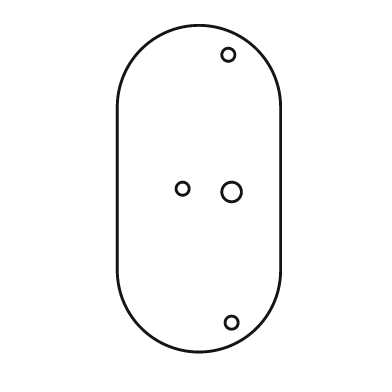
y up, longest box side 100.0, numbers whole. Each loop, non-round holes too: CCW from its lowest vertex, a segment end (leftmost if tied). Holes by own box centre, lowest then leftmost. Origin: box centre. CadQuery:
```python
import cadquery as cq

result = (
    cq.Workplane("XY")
    .moveTo(-25.0, -25.0)
    .threePointArc((0.0, -50.0), (25.0, -25.0))
    .lineTo(25.0, 25.0)
    .threePointArc((0.0, 50.0), (-25.0, 25.0))
    .close()
    .moveTo(10.0, -41.0)
    .circle(2.0)
    .moveTo(10.0, -1.0)
    .circle(3.0)
    .moveTo(-5.0, 0.0)
    .circle(2.0)
    .moveTo(9.0, 41.0)
    .circle(2.0)
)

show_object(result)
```